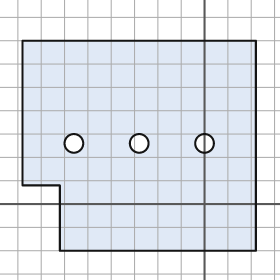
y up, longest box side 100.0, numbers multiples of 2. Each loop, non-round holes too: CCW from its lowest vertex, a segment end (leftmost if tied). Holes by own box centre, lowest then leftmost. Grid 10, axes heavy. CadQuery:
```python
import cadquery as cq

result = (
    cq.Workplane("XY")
    .moveTo(-62.0, -20.0)
    .lineTo(22.0, -20.0)
    .lineTo(22.0, 70.0)
    .lineTo(-78.0, 70.0)
    .lineTo(-78.0, 8.0)
    .lineTo(-62.0, 8.0)
    .close()
    .moveTo(-56.0, 26.0)
    .circle(4.0)
    .moveTo(-28.0, 26.0)
    .circle(4.0)
    .moveTo(0.0, 26.0)
    .circle(4.0)
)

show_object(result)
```